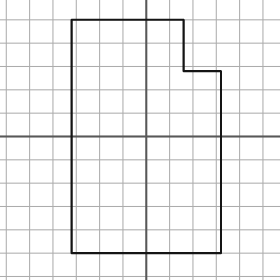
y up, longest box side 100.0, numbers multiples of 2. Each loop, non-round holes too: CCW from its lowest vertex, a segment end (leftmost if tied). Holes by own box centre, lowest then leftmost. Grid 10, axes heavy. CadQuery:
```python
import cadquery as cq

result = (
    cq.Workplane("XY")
    .moveTo(-32.0, -50.0)
    .lineTo(32.0, -50.0)
    .lineTo(32.0, 28.0)
    .lineTo(16.0, 28.0)
    .lineTo(16.0, 50.0)
    .lineTo(-32.0, 50.0)
    .close()
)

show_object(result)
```